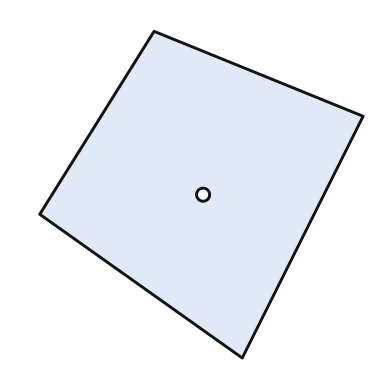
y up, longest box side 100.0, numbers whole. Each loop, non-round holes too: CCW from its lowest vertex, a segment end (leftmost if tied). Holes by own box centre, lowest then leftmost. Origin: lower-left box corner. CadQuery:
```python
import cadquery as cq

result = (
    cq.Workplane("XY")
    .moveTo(62.0, 0.0)
    .lineTo(99.0, 74.0)
    .lineTo(35.0, 100.0)
    .lineTo(0.0, 44.0)
    .close()
    .moveTo(50.0, 50.0)
    .circle(2.0)
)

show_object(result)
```